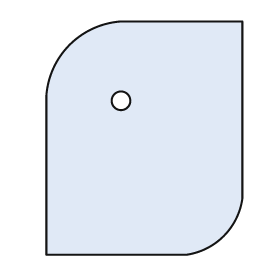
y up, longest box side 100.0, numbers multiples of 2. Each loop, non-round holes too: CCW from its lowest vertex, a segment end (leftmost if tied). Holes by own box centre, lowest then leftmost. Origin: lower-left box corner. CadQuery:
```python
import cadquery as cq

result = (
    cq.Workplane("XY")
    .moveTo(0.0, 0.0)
    .lineTo(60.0, 0.0)
    .threePointArc((76.0, 8.0), (84.0, 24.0))
    .lineTo(84.0, 100.0)
    .lineTo(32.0, 100.0)
    .threePointArc((10.0, 90.0), (0.0, 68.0))
    .close()
    .moveTo(32.0, 66.0)
    .circle(4.0)
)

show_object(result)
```